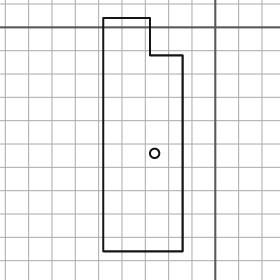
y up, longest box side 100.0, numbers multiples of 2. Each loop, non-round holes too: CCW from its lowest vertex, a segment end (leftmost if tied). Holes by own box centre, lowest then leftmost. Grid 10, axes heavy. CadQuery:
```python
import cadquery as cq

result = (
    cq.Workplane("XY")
    .moveTo(-48.0, -96.0)
    .lineTo(-14.0, -96.0)
    .lineTo(-14.0, -12.0)
    .lineTo(-28.0, -12.0)
    .lineTo(-28.0, 4.0)
    .lineTo(-48.0, 4.0)
    .close()
    .moveTo(-26.0, -54.0)
    .circle(2.0)
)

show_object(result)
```